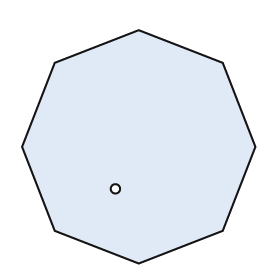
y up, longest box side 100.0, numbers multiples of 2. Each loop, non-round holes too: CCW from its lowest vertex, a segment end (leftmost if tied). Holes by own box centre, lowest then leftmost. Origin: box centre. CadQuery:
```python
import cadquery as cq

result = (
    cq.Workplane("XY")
    .moveTo(0.0, -50.0)
    .lineTo(36.0, -36.0)
    .lineTo(50.0, 0.0)
    .lineTo(36.0, 36.0)
    .lineTo(0.0, 50.0)
    .lineTo(-36.0, 36.0)
    .lineTo(-50.0, 0.0)
    .lineTo(-36.0, -36.0)
    .close()
    .moveTo(-10.0, -18.0)
    .circle(2.0)
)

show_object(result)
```